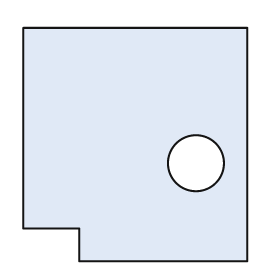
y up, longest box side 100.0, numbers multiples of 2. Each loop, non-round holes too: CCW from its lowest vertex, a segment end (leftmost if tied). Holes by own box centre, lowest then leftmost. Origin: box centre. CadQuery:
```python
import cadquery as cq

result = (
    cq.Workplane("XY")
    .moveTo(-24.0, -50.0)
    .lineTo(48.0, -50.0)
    .lineTo(48.0, 50.0)
    .lineTo(-48.0, 50.0)
    .lineTo(-48.0, -36.0)
    .lineTo(-24.0, -36.0)
    .close()
    .moveTo(26.0, -8.0)
    .circle(12.0)
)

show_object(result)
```